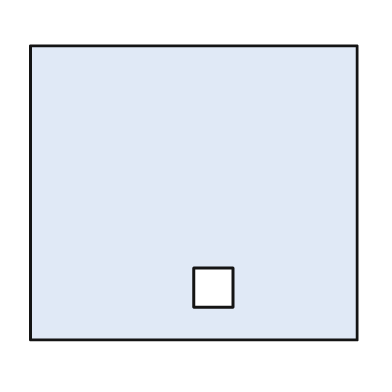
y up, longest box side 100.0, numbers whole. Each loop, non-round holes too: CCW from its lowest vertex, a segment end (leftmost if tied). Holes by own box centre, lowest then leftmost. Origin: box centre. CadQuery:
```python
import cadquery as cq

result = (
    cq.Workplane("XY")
    .moveTo(-50.0, -45.0)
    .lineTo(50.0, -45.0)
    .lineTo(50.0, 45.0)
    .lineTo(-50.0, 45.0)
    .close()
    .moveTo(0.0, -35.0)
    .lineTo(12.0, -35.0)
    .lineTo(12.0, -23.0)
    .lineTo(0.0, -23.0)
    .close()
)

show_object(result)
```